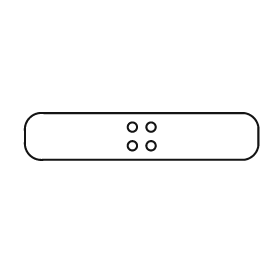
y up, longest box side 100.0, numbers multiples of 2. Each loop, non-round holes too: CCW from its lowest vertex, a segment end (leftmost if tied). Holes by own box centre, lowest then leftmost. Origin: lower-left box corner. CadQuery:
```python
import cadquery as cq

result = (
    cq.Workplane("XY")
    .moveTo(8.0, 0.0)
    .lineTo(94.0, 0.0)
    .threePointArc((98.0, 2.0), (100.0, 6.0))
    .lineTo(100.0, 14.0)
    .threePointArc((98.0, 18.0), (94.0, 20.0))
    .lineTo(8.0, 20.0)
    .threePointArc((2.0, 18.0), (0.0, 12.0))
    .lineTo(0.0, 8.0)
    .threePointArc((2.0, 2.0), (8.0, 0.0))
    .close()
    .moveTo(46.0, 6.0)
    .circle(2.0)
    .moveTo(54.0, 6.0)
    .circle(2.0)
    .moveTo(46.0, 14.0)
    .circle(2.0)
    .moveTo(54.0, 14.0)
    .circle(2.0)
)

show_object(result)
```